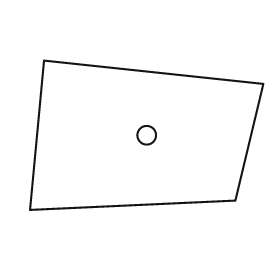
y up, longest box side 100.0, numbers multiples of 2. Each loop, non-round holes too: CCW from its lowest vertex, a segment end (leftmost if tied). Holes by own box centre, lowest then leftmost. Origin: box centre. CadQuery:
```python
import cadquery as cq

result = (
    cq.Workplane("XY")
    .moveTo(-50.0, -32.0)
    .lineTo(38.0, -28.0)
    .lineTo(50.0, 22.0)
    .lineTo(-44.0, 32.0)
    .close()
    .moveTo(0.0, 0.0)
    .circle(4.0)
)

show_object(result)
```